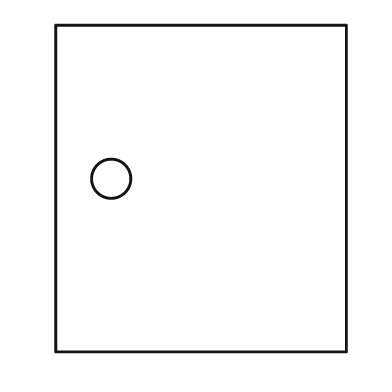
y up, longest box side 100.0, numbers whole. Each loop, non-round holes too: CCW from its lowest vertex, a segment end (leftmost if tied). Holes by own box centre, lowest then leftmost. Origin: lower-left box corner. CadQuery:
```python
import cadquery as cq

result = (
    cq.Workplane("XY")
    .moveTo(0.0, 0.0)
    .lineTo(89.0, 0.0)
    .lineTo(89.0, 100.0)
    .lineTo(0.0, 100.0)
    .close()
    .moveTo(17.0, 53.0)
    .circle(6.0)
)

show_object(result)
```